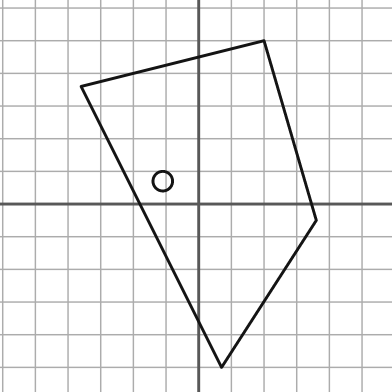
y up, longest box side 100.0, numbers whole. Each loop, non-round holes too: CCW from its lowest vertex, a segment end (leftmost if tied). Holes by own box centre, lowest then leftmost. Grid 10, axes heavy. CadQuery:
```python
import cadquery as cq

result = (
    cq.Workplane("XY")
    .moveTo(7.0, -50.0)
    .lineTo(36.0, -5.0)
    .lineTo(20.0, 50.0)
    .lineTo(-36.0, 36.0)
    .close()
    .moveTo(-11.0, 7.0)
    .circle(3.0)
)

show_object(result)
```